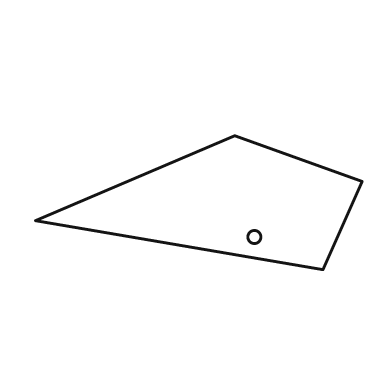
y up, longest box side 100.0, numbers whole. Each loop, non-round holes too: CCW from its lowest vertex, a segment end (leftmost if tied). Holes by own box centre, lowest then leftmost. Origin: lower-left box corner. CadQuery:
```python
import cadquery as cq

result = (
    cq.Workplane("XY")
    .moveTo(88.0, 0.0)
    .lineTo(100.0, 27.0)
    .lineTo(61.0, 41.0)
    .lineTo(0.0, 15.0)
    .close()
    .moveTo(67.0, 10.0)
    .circle(2.0)
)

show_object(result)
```